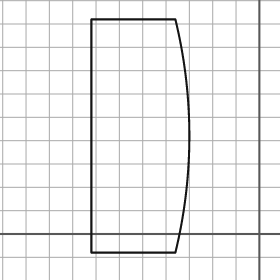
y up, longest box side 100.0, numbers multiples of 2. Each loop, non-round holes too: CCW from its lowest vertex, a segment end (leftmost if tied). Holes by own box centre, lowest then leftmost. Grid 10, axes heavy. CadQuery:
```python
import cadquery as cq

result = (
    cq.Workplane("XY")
    .moveTo(-72.0, -8.0)
    .lineTo(-36.0, -8.0)
    .threePointArc((-30.0, 42.0), (-36.0, 92.0))
    .lineTo(-72.0, 92.0)
    .close()
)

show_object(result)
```